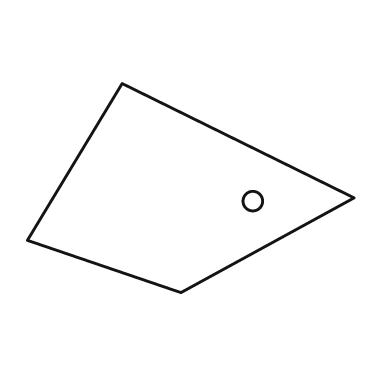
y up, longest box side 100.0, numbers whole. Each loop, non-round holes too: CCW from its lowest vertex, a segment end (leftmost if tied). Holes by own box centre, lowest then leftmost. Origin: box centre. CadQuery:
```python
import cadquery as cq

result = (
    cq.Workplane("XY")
    .moveTo(-3.0, -32.0)
    .lineTo(50.0, -3.0)
    .lineTo(-21.0, 32.0)
    .lineTo(-50.0, -16.0)
    .close()
    .moveTo(19.0, -4.0)
    .circle(3.0)
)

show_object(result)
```